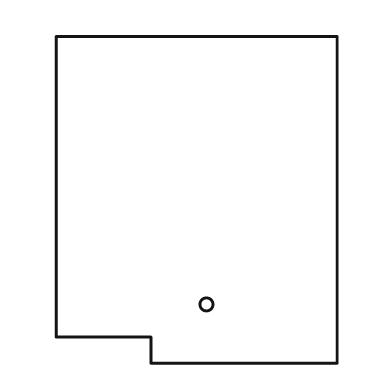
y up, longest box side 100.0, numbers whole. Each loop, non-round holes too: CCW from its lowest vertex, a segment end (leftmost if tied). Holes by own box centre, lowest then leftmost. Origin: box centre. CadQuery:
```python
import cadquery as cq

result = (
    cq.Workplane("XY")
    .moveTo(-14.0, -50.0)
    .lineTo(43.0, -50.0)
    .lineTo(43.0, 50.0)
    .lineTo(-43.0, 50.0)
    .lineTo(-43.0, -42.0)
    .lineTo(-14.0, -42.0)
    .close()
    .moveTo(3.0, -32.0)
    .circle(2.0)
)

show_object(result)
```